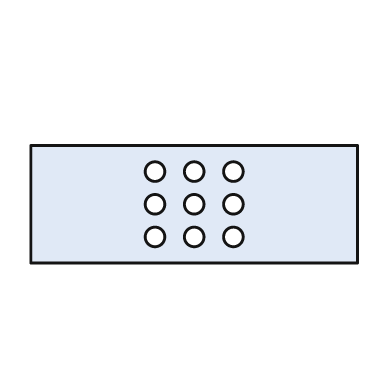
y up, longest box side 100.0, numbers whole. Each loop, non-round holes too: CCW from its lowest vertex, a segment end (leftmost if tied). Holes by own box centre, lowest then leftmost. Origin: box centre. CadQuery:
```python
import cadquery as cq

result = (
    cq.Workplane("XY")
    .moveTo(-50.0, -18.0)
    .lineTo(50.0, -18.0)
    .lineTo(50.0, 18.0)
    .lineTo(-50.0, 18.0)
    .close()
    .moveTo(-12.0, -10.0)
    .circle(3.0)
    .moveTo(0.0, -10.0)
    .circle(3.0)
    .moveTo(12.0, -10.0)
    .circle(3.0)
    .moveTo(-12.0, 0.0)
    .circle(3.0)
    .moveTo(0.0, 0.0)
    .circle(3.0)
    .moveTo(12.0, 0.0)
    .circle(3.0)
    .moveTo(-12.0, 10.0)
    .circle(3.0)
    .moveTo(0.0, 10.0)
    .circle(3.0)
    .moveTo(12.0, 10.0)
    .circle(3.0)
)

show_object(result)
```